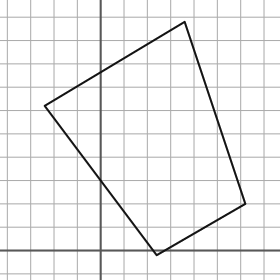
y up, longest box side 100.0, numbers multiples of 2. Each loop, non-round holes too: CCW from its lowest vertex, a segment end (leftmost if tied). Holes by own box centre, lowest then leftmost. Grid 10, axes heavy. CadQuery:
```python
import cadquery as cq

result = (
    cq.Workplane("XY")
    .moveTo(24.0, -2.0)
    .lineTo(62.0, 20.0)
    .lineTo(36.0, 98.0)
    .lineTo(-24.0, 62.0)
    .close()
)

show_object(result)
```